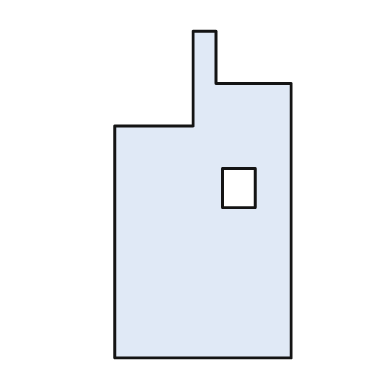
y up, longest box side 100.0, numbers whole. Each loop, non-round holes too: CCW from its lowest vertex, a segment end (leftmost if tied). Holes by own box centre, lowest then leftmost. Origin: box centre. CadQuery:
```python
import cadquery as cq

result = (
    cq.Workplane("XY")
    .moveTo(-27.0, -50.0)
    .lineTo(27.0, -50.0)
    .lineTo(27.0, 34.0)
    .lineTo(4.0, 34.0)
    .lineTo(4.0, 50.0)
    .lineTo(-3.0, 50.0)
    .lineTo(-3.0, 21.0)
    .lineTo(-27.0, 21.0)
    .close()
    .moveTo(6.0, -4.0)
    .lineTo(16.0, -4.0)
    .lineTo(16.0, 8.0)
    .lineTo(6.0, 8.0)
    .close()
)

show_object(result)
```